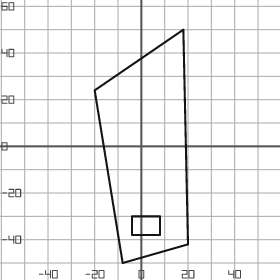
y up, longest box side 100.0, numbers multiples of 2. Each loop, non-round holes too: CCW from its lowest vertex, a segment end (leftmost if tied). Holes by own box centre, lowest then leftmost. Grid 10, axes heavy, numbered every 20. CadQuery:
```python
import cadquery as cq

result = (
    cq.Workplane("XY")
    .moveTo(-8.0, -50.0)
    .lineTo(20.0, -42.0)
    .lineTo(18.0, 50.0)
    .lineTo(-20.0, 24.0)
    .close()
    .moveTo(-4.0, -38.0)
    .lineTo(8.0, -38.0)
    .lineTo(8.0, -30.0)
    .lineTo(-4.0, -30.0)
    .close()
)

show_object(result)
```